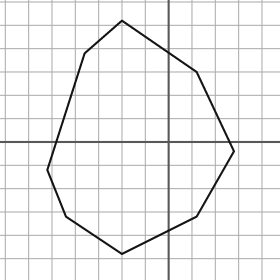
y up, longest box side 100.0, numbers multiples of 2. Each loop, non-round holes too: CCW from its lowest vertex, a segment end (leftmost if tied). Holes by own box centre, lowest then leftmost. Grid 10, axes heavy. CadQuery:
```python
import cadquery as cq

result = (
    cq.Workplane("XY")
    .moveTo(-20.0, -48.0)
    .lineTo(12.0, -32.0)
    .lineTo(28.0, -4.0)
    .lineTo(12.0, 30.0)
    .lineTo(-20.0, 52.0)
    .lineTo(-36.0, 38.0)
    .lineTo(-52.0, -12.0)
    .lineTo(-44.0, -32.0)
    .close()
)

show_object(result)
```